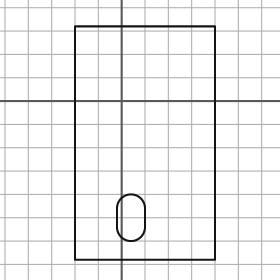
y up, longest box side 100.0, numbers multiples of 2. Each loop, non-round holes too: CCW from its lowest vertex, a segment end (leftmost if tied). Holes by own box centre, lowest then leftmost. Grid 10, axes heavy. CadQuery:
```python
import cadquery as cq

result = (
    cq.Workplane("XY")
    .moveTo(-20.0, -68.0)
    .lineTo(40.0, -68.0)
    .lineTo(40.0, 32.0)
    .lineTo(-20.0, 32.0)
    .close()
    .moveTo(-2.0, -54.0)
    .threePointArc((4.0, -60.0), (10.0, -54.0))
    .lineTo(10.0, -46.0)
    .threePointArc((4.0, -40.0), (-2.0, -46.0))
    .close()
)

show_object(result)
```